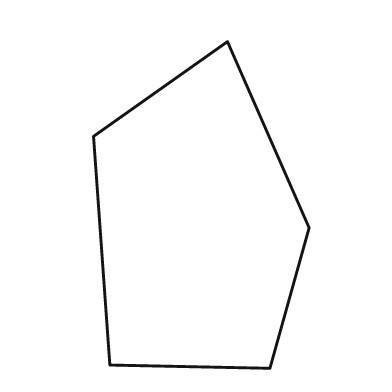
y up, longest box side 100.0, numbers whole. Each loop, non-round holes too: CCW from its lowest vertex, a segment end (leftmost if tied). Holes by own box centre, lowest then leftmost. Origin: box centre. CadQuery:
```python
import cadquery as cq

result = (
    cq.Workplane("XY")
    .moveTo(21.0, -50.0)
    .lineTo(33.0, -7.0)
    .lineTo(8.0, 50.0)
    .lineTo(-33.0, 21.0)
    .lineTo(-28.0, -49.0)
    .close()
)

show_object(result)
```